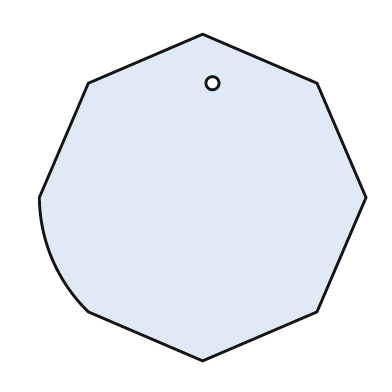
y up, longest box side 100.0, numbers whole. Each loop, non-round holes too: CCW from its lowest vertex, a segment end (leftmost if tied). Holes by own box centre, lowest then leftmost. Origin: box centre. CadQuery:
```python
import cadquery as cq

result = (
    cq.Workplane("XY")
    .moveTo(0.0, -50.0)
    .lineTo(35.0, -35.0)
    .lineTo(50.0, 0.0)
    .lineTo(35.0, 35.0)
    .lineTo(0.0, 50.0)
    .lineTo(-35.0, 35.0)
    .lineTo(-50.0, 0.0)
    .threePointArc((-46.0, -19.0), (-35.0, -35.0))
    .close()
    .moveTo(3.0, 35.0)
    .circle(2.0)
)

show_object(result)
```